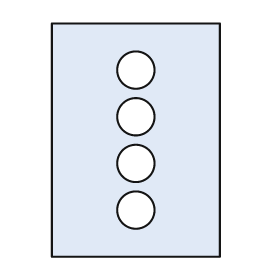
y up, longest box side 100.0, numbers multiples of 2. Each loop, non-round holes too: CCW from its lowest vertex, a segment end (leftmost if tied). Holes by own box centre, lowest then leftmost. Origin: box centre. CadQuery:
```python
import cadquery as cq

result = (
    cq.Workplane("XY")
    .moveTo(-36.0, -50.0)
    .lineTo(36.0, -50.0)
    .lineTo(36.0, 50.0)
    .lineTo(-36.0, 50.0)
    .close()
    .moveTo(0.0, -30.0)
    .circle(8.0)
    .moveTo(0.0, -10.0)
    .circle(8.0)
    .moveTo(0.0, 10.0)
    .circle(8.0)
    .moveTo(0.0, 30.0)
    .circle(8.0)
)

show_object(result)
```